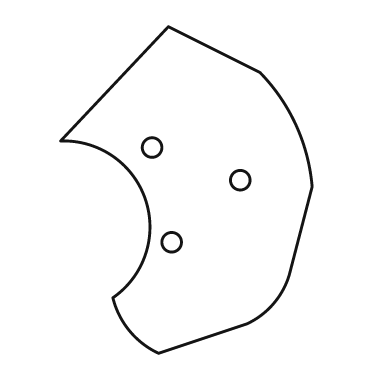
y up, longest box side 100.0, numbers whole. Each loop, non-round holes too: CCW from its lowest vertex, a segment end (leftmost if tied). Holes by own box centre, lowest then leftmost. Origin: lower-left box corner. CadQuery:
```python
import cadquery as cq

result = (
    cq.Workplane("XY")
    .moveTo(30.0, 0.0)
    .lineTo(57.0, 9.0)
    .threePointArc((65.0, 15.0), (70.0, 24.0))
    .lineTo(77.0, 51.0)
    .threePointArc((72.0, 70.0), (61.0, 86.0))
    .lineTo(33.0, 100.0)
    .lineTo(0.0, 65.0)
    .threePointArc((26.0, 47.0), (16.0, 17.0))
    .threePointArc((21.0, 7.0), (30.0, 0.0))
    .close()
    .moveTo(34.0, 34.0)
    .circle(3.0)
    .moveTo(55.0, 53.0)
    .circle(3.0)
    .moveTo(28.0, 63.0)
    .circle(3.0)
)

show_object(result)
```